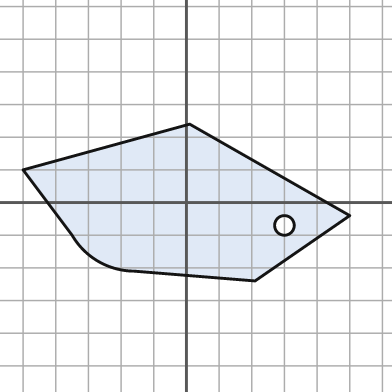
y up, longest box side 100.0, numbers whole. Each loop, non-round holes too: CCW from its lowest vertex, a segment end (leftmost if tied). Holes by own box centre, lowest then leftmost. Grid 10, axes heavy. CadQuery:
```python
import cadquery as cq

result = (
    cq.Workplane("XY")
    .moveTo(21.0, -24.0)
    .lineTo(50.0, -4.0)
    .lineTo(1.0, 24.0)
    .lineTo(-50.0, 10.0)
    .lineTo(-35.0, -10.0)
    .threePointArc((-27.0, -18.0), (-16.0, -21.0))
    .close()
    .moveTo(30.0, -7.0)
    .circle(3.0)
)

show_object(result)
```